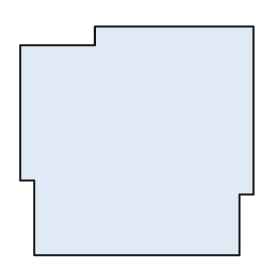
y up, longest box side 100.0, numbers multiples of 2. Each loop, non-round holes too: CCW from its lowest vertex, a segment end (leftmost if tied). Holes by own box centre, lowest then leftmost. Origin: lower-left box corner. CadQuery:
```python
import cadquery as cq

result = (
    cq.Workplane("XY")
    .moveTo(6.0, 0.0)
    .lineTo(94.0, 0.0)
    .lineTo(94.0, 26.0)
    .lineTo(100.0, 26.0)
    .lineTo(100.0, 98.0)
    .lineTo(32.0, 98.0)
    .lineTo(32.0, 90.0)
    .lineTo(0.0, 90.0)
    .lineTo(0.0, 32.0)
    .lineTo(6.0, 32.0)
    .close()
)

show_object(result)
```